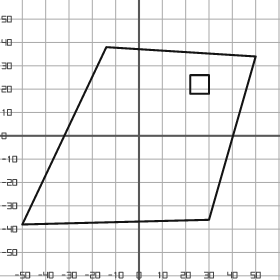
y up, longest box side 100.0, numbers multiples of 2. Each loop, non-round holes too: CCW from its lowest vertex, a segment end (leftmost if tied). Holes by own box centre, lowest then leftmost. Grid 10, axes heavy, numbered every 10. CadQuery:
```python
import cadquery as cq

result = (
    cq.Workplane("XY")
    .moveTo(-50.0, -38.0)
    .lineTo(30.0, -36.0)
    .lineTo(50.0, 34.0)
    .lineTo(-14.0, 38.0)
    .close()
    .moveTo(22.0, 18.0)
    .lineTo(30.0, 18.0)
    .lineTo(30.0, 26.0)
    .lineTo(22.0, 26.0)
    .close()
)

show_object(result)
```